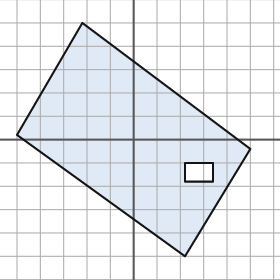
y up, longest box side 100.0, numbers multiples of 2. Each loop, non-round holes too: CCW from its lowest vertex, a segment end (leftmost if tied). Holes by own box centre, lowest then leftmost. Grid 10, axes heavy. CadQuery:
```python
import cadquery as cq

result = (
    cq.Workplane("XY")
    .moveTo(22.0, -50.0)
    .lineTo(50.0, -4.0)
    .lineTo(-22.0, 50.0)
    .lineTo(-50.0, 2.0)
    .close()
    .moveTo(22.0, -18.0)
    .lineTo(34.0, -18.0)
    .lineTo(34.0, -10.0)
    .lineTo(22.0, -10.0)
    .close()
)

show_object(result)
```